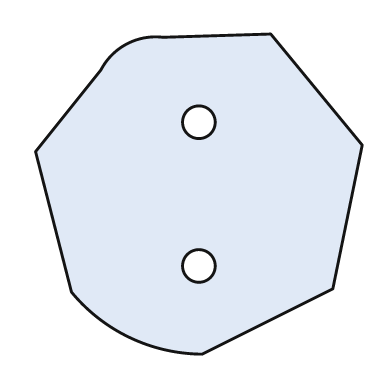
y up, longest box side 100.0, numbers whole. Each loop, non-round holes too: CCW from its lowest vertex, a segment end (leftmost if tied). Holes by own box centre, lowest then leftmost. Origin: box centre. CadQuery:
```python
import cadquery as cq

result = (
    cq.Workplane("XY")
    .moveTo(1.0, -49.0)
    .lineTo(41.0, -29.0)
    .lineTo(50.0, 15.0)
    .lineTo(22.0, 49.0)
    .lineTo(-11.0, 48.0)
    .threePointArc((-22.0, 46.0), (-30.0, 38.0))
    .lineTo(-50.0, 13.0)
    .lineTo(-39.0, -30.0)
    .threePointArc((-21.0, -44.0), (1.0, -49.0))
    .close()
    .moveTo(0.0, -22.0)
    .circle(5.0)
    .moveTo(0.0, 22.0)
    .circle(5.0)
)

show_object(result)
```